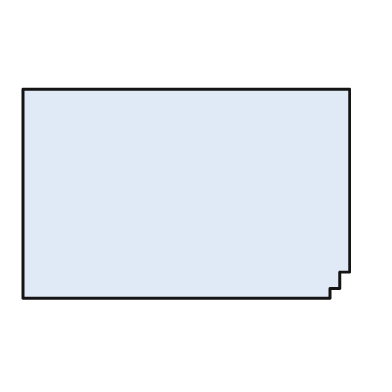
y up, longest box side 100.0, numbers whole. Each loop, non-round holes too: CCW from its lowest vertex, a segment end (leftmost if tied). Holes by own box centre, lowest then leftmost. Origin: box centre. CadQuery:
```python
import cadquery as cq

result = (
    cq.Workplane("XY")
    .moveTo(-50.0, -32.0)
    .lineTo(44.0, -32.0)
    .lineTo(44.0, -29.0)
    .lineTo(47.0, -29.0)
    .lineTo(47.0, -24.0)
    .lineTo(50.0, -24.0)
    .lineTo(50.0, 32.0)
    .lineTo(-50.0, 32.0)
    .close()
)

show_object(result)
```